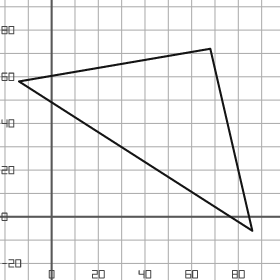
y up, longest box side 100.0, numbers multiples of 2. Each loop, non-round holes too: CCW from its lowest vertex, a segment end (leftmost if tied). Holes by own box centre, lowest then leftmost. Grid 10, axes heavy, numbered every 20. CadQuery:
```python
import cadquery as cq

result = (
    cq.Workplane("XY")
    .moveTo(86.0, -6.0)
    .lineTo(68.0, 72.0)
    .lineTo(-14.0, 58.0)
    .close()
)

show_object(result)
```